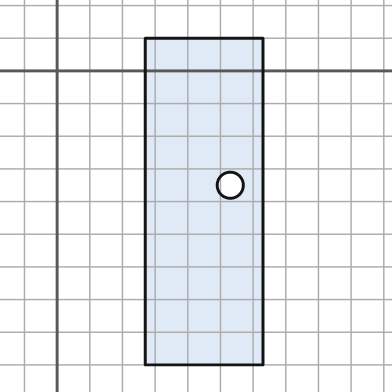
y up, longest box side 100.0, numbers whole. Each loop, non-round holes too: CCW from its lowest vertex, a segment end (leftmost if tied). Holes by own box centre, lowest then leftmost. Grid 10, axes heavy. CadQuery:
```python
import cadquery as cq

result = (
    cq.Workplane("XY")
    .moveTo(27.0, -90.0)
    .lineTo(63.0, -90.0)
    .lineTo(63.0, 10.0)
    .lineTo(27.0, 10.0)
    .close()
    .moveTo(53.0, -35.0)
    .circle(4.0)
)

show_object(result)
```